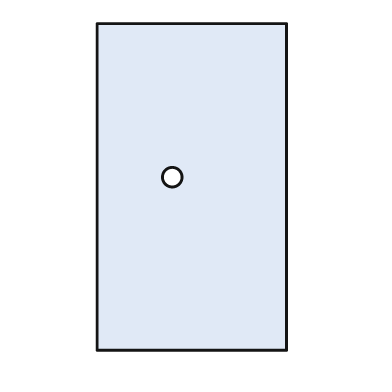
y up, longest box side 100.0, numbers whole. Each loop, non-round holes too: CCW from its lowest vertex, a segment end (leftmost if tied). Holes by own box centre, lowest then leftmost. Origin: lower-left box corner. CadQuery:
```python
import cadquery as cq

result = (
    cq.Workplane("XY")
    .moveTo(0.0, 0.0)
    .lineTo(58.0, 0.0)
    .lineTo(58.0, 100.0)
    .lineTo(0.0, 100.0)
    .close()
    .moveTo(23.0, 53.0)
    .circle(3.0)
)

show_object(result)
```